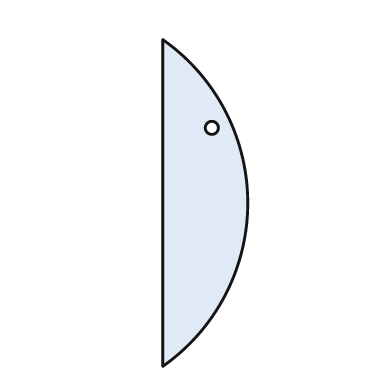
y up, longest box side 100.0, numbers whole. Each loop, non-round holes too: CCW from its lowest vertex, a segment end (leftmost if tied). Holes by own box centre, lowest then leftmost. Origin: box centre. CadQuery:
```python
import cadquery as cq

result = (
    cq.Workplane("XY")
    .moveTo(-13.0, -50.0)
    .threePointArc((13.0, 0.0), (-13.0, 50.0))
    .close()
    .moveTo(2.0, 23.0)
    .circle(2.0)
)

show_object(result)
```